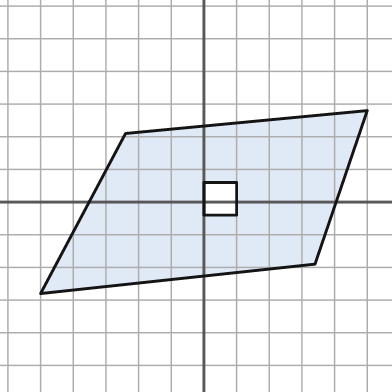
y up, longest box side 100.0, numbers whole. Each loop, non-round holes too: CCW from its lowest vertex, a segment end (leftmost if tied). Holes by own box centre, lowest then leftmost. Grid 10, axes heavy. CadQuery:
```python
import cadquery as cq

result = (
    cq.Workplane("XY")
    .moveTo(-50.0, -28.0)
    .lineTo(34.0, -19.0)
    .lineTo(50.0, 28.0)
    .lineTo(-24.0, 21.0)
    .close()
    .moveTo(0.0, -4.0)
    .lineTo(10.0, -4.0)
    .lineTo(10.0, 6.0)
    .lineTo(0.0, 6.0)
    .close()
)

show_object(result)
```